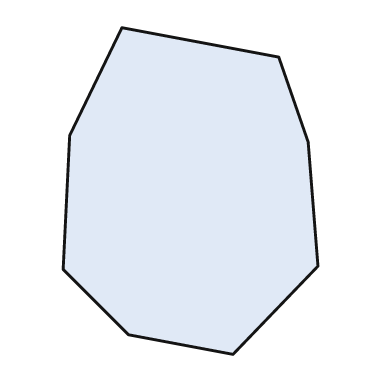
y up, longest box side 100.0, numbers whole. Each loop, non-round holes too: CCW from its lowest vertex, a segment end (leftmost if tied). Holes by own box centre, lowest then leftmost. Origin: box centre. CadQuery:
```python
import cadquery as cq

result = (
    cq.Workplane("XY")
    .moveTo(13.0, -50.0)
    .lineTo(39.0, -23.0)
    .lineTo(36.0, 15.0)
    .lineTo(27.0, 41.0)
    .lineTo(-21.0, 50.0)
    .lineTo(-37.0, 17.0)
    .lineTo(-39.0, -24.0)
    .lineTo(-19.0, -44.0)
    .close()
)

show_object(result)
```